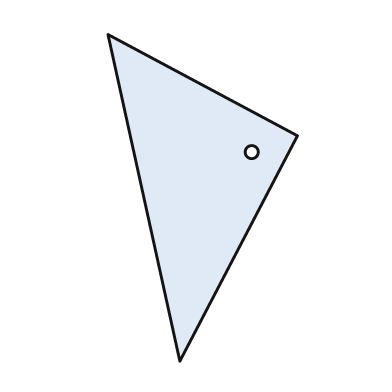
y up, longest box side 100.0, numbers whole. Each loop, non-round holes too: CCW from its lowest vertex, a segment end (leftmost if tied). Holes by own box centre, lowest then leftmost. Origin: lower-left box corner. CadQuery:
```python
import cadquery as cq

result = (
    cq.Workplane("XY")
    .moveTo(22.0, 0.0)
    .lineTo(58.0, 69.0)
    .lineTo(0.0, 100.0)
    .close()
    .moveTo(44.0, 64.0)
    .circle(2.0)
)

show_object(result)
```